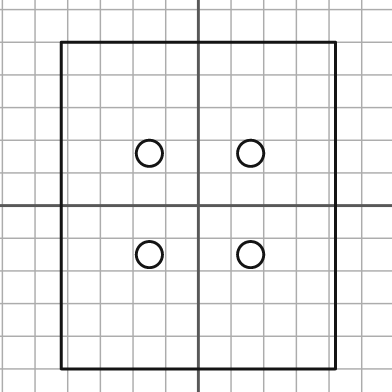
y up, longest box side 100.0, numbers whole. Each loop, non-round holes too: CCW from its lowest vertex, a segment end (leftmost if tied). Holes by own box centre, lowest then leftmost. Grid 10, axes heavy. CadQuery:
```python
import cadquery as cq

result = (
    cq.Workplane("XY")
    .moveTo(-42.0, -50.0)
    .lineTo(42.0, -50.0)
    .lineTo(42.0, 50.0)
    .lineTo(-42.0, 50.0)
    .close()
    .moveTo(-15.0, -15.0)
    .circle(4.0)
    .moveTo(16.0, -15.0)
    .circle(4.0)
    .moveTo(-15.0, 16.0)
    .circle(4.0)
    .moveTo(16.0, 16.0)
    .circle(4.0)
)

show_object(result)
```